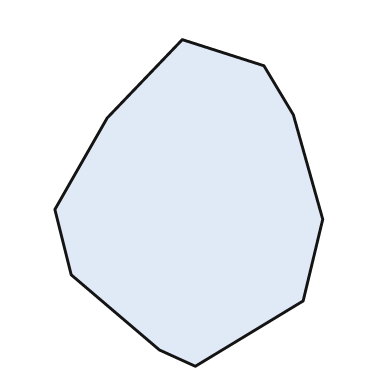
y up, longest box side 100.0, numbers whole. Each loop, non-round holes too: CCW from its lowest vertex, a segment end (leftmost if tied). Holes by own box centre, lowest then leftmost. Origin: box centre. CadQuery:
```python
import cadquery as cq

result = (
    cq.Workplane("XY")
    .moveTo(2.0, -50.0)
    .lineTo(35.0, -30.0)
    .lineTo(41.0, -5.0)
    .lineTo(32.0, 27.0)
    .lineTo(23.0, 42.0)
    .lineTo(-2.0, 50.0)
    .lineTo(-25.0, 26.0)
    .lineTo(-41.0, -2.0)
    .lineTo(-36.0, -22.0)
    .lineTo(-9.0, -45.0)
    .close()
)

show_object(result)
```